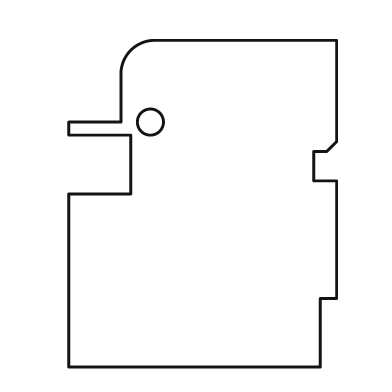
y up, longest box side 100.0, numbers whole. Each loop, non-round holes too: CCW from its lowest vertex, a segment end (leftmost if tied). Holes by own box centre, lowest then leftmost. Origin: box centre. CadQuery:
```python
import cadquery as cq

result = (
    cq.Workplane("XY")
    .moveTo(-41.0, -50.0)
    .lineTo(36.0, -50.0)
    .lineTo(36.0, -29.0)
    .lineTo(41.0, -29.0)
    .lineTo(41.0, 7.0)
    .lineTo(34.0, 7.0)
    .lineTo(34.0, 16.0)
    .lineTo(38.0, 16.0)
    .lineTo(41.0, 19.0)
    .lineTo(41.0, 50.0)
    .lineTo(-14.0, 50.0)
    .threePointArc((-22.0, 47.0), (-25.0, 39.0))
    .lineTo(-25.0, 25.0)
    .lineTo(-41.0, 25.0)
    .lineTo(-41.0, 21.0)
    .lineTo(-22.0, 21.0)
    .lineTo(-22.0, 3.0)
    .lineTo(-41.0, 3.0)
    .close()
    .moveTo(-16.0, 25.0)
    .circle(4.0)
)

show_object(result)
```